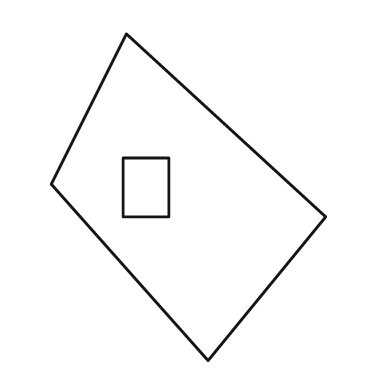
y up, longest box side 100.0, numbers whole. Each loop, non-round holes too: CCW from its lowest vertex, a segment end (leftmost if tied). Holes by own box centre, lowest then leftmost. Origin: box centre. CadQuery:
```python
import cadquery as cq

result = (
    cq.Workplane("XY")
    .moveTo(6.0, -50.0)
    .lineTo(42.0, -6.0)
    .lineTo(-19.0, 50.0)
    .lineTo(-42.0, 4.0)
    .close()
    .moveTo(-20.0, -6.0)
    .lineTo(-6.0, -6.0)
    .lineTo(-6.0, 12.0)
    .lineTo(-20.0, 12.0)
    .close()
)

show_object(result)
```